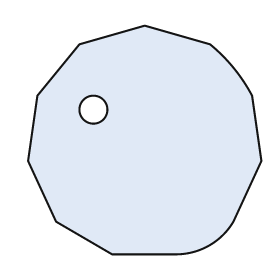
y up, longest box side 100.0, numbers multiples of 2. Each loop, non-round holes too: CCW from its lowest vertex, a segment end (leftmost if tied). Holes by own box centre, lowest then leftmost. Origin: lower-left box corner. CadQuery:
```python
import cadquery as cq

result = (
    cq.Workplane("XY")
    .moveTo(36.0, 0.0)
    .lineTo(64.0, 0.0)
    .threePointArc((78.0, 4.0), (88.0, 14.0))
    .lineTo(100.0, 40.0)
    .lineTo(96.0, 68.0)
    .threePointArc((88.0, 80.0), (78.0, 90.0))
    .lineTo(50.0, 98.0)
    .lineTo(22.0, 90.0)
    .lineTo(4.0, 68.0)
    .lineTo(0.0, 40.0)
    .lineTo(12.0, 14.0)
    .close()
    .moveTo(28.0, 62.0)
    .circle(6.0)
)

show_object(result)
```